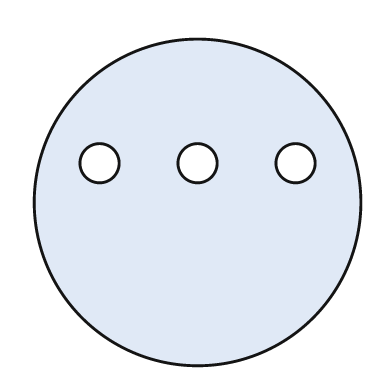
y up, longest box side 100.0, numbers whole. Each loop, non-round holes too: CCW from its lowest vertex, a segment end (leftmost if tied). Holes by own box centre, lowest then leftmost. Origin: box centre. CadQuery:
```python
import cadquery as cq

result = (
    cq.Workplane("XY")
    .moveTo(0.0, 0.0)
    .circle(50.0)
    .moveTo(-30.0, 12.0)
    .circle(6.0)
    .moveTo(0.0, 12.0)
    .circle(6.0)
    .moveTo(30.0, 12.0)
    .circle(6.0)
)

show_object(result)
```